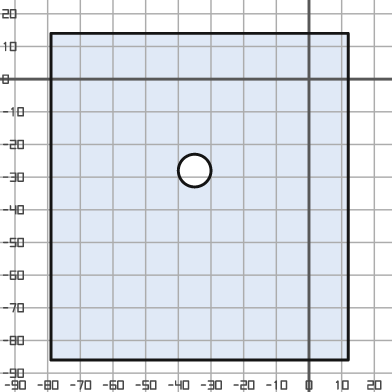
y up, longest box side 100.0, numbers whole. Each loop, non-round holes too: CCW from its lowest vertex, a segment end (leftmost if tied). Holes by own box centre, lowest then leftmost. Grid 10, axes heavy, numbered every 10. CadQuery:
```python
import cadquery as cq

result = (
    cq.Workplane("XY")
    .moveTo(-79.0, -86.0)
    .lineTo(12.0, -86.0)
    .lineTo(12.0, 14.0)
    .lineTo(-79.0, 14.0)
    .close()
    .moveTo(-35.0, -28.0)
    .circle(5.0)
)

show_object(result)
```